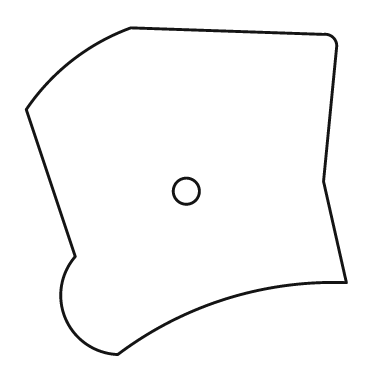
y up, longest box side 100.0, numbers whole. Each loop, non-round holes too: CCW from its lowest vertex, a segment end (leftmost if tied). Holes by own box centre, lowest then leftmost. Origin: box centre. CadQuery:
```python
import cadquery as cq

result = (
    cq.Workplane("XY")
    .moveTo(-21.0, -50.0)
    .threePointArc((12.0, -33.0), (49.0, -28.0))
    .lineTo(42.0, 3.0)
    .lineTo(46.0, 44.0)
    .threePointArc((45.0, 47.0), (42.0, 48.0))
    .lineTo(-17.0, 50.0)
    .threePointArc((-35.0, 40.0), (-49.0, 25.0))
    .lineTo(-34.0, -20.0)
    .threePointArc((-37.0, -39.0), (-21.0, -50.0))
    .close()
    .moveTo(0.0, 0.0)
    .circle(4.0)
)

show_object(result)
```